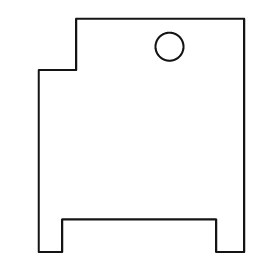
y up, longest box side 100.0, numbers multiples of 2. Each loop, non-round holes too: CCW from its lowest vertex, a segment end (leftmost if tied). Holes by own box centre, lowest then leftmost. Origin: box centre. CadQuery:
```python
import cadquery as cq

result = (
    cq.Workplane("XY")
    .moveTo(-44.0, -50.0)
    .lineTo(-34.0, -50.0)
    .lineTo(-34.0, -36.0)
    .lineTo(32.0, -36.0)
    .lineTo(32.0, -50.0)
    .lineTo(44.0, -50.0)
    .lineTo(44.0, 50.0)
    .lineTo(-28.0, 50.0)
    .lineTo(-28.0, 28.0)
    .lineTo(-44.0, 28.0)
    .close()
    .moveTo(12.0, 38.0)
    .circle(6.0)
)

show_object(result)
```